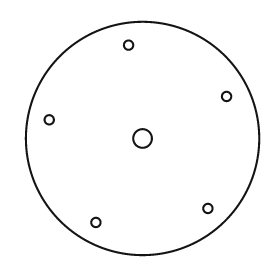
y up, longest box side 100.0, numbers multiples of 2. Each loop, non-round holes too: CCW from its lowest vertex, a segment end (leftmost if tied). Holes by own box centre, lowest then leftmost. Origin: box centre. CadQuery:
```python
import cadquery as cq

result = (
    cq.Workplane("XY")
    .moveTo(0.0, 0.0)
    .circle(50.0)
    .moveTo(-20.0, -36.0)
    .circle(2.0)
    .moveTo(28.0, -30.0)
    .circle(2.0)
    .moveTo(0.0, 0.0)
    .circle(4.0)
    .moveTo(-40.0, 8.0)
    .circle(2.0)
    .moveTo(36.0, 18.0)
    .circle(2.0)
    .moveTo(-6.0, 40.0)
    .circle(2.0)
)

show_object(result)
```